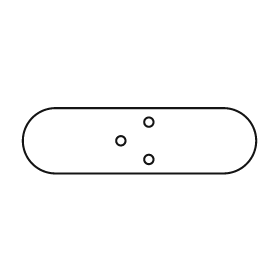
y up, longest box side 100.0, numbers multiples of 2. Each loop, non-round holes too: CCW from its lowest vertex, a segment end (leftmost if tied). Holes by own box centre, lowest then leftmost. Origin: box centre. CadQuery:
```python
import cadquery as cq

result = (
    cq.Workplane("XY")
    .moveTo(-36.0, -14.0)
    .lineTo(36.0, -14.0)
    .threePointArc((50.0, 0.0), (36.0, 14.0))
    .lineTo(-36.0, 14.0)
    .threePointArc((-50.0, 0.0), (-36.0, -14.0))
    .close()
    .moveTo(4.0, -8.0)
    .circle(2.0)
    .moveTo(-8.0, 0.0)
    .circle(2.0)
    .moveTo(4.0, 8.0)
    .circle(2.0)
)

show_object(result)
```